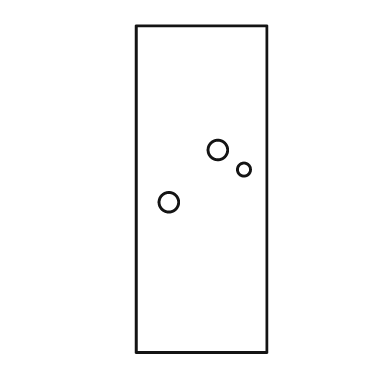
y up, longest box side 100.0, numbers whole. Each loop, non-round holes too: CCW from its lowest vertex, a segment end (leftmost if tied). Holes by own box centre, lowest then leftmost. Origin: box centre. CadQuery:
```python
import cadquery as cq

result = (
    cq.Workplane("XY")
    .moveTo(-20.0, -50.0)
    .lineTo(20.0, -50.0)
    .lineTo(20.0, 50.0)
    .lineTo(-20.0, 50.0)
    .close()
    .moveTo(-10.0, -4.0)
    .circle(3.0)
    .moveTo(13.0, 6.0)
    .circle(2.0)
    .moveTo(5.0, 12.0)
    .circle(3.0)
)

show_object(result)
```